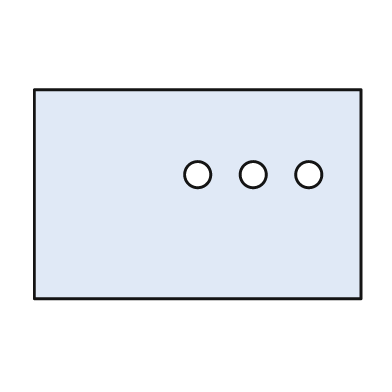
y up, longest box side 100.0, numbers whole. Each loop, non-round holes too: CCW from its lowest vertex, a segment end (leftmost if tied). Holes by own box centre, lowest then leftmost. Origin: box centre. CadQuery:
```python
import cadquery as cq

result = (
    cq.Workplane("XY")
    .moveTo(-50.0, -32.0)
    .lineTo(50.0, -32.0)
    .lineTo(50.0, 32.0)
    .lineTo(-50.0, 32.0)
    .close()
    .moveTo(0.0, 6.0)
    .circle(4.0)
    .moveTo(17.0, 6.0)
    .circle(4.0)
    .moveTo(34.0, 6.0)
    .circle(4.0)
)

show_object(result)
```